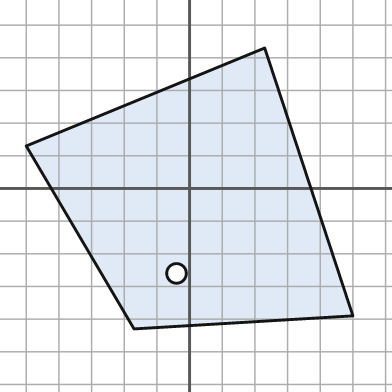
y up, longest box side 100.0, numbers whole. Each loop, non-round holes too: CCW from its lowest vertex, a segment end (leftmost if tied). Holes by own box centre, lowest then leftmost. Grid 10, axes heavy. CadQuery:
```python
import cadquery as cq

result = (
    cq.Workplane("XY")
    .moveTo(-17.0, -43.0)
    .lineTo(50.0, -39.0)
    .lineTo(23.0, 43.0)
    .lineTo(-50.0, 13.0)
    .close()
    .moveTo(-4.0, -26.0)
    .circle(3.0)
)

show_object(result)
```